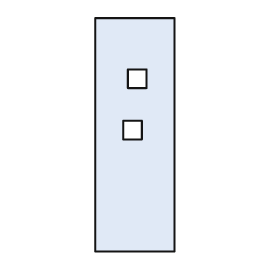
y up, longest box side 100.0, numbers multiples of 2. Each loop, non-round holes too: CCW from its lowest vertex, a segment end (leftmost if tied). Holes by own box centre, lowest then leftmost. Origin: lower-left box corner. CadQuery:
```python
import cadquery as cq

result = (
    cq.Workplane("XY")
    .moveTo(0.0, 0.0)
    .lineTo(34.0, 0.0)
    .lineTo(34.0, 100.0)
    .lineTo(0.0, 100.0)
    .close()
    .moveTo(12.0, 48.0)
    .lineTo(20.0, 48.0)
    .lineTo(20.0, 56.0)
    .lineTo(12.0, 56.0)
    .close()
    .moveTo(14.0, 70.0)
    .lineTo(22.0, 70.0)
    .lineTo(22.0, 78.0)
    .lineTo(14.0, 78.0)
    .close()
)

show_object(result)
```